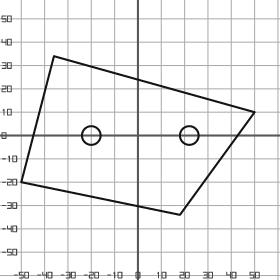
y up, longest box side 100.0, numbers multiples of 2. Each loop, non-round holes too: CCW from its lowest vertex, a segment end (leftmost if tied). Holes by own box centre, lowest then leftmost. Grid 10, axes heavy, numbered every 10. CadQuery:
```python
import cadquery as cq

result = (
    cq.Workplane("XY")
    .moveTo(18.0, -34.0)
    .lineTo(50.0, 10.0)
    .lineTo(-36.0, 34.0)
    .lineTo(-50.0, -20.0)
    .close()
    .moveTo(-20.0, 0.0)
    .circle(4.0)
    .moveTo(22.0, 0.0)
    .circle(4.0)
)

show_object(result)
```